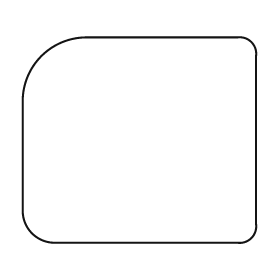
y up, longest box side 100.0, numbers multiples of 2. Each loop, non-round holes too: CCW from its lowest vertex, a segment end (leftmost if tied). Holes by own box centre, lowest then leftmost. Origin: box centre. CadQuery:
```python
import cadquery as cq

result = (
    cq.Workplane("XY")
    .moveTo(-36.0, -44.0)
    .lineTo(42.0, -44.0)
    .threePointArc((48.0, -42.0), (50.0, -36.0))
    .lineTo(50.0, 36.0)
    .threePointArc((48.0, 42.0), (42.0, 44.0))
    .lineTo(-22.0, 44.0)
    .threePointArc((-42.0, 36.0), (-50.0, 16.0))
    .lineTo(-50.0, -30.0)
    .threePointArc((-46.0, -40.0), (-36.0, -44.0))
    .close()
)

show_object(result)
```